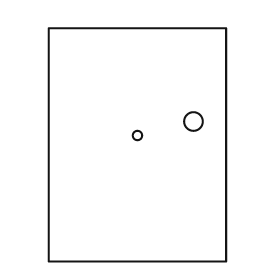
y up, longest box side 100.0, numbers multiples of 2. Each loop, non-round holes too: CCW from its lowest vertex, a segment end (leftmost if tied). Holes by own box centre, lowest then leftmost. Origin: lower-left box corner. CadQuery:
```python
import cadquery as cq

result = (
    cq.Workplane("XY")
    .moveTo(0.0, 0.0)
    .lineTo(76.0, 0.0)
    .lineTo(76.0, 100.0)
    .lineTo(0.0, 100.0)
    .close()
    .moveTo(38.0, 54.0)
    .circle(2.0)
    .moveTo(62.0, 60.0)
    .circle(4.0)
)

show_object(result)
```